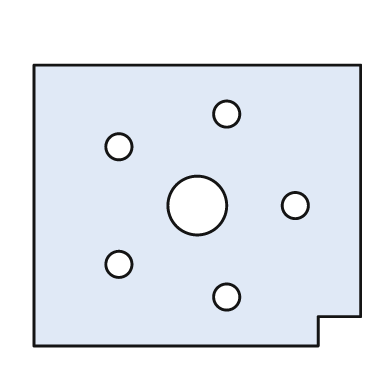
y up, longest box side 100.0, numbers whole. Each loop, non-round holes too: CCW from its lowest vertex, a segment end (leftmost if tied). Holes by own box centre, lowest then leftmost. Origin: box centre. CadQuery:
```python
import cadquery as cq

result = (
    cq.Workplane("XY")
    .moveTo(-50.0, -43.0)
    .lineTo(37.0, -43.0)
    .lineTo(37.0, -34.0)
    .lineTo(50.0, -34.0)
    .lineTo(50.0, 43.0)
    .lineTo(-50.0, 43.0)
    .close()
    .moveTo(9.0, -28.0)
    .circle(4.0)
    .moveTo(-24.0, -18.0)
    .circle(4.0)
    .moveTo(0.0, 0.0)
    .circle(9.0)
    .moveTo(30.0, 0.0)
    .circle(4.0)
    .moveTo(-24.0, 18.0)
    .circle(4.0)
    .moveTo(9.0, 28.0)
    .circle(4.0)
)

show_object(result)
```